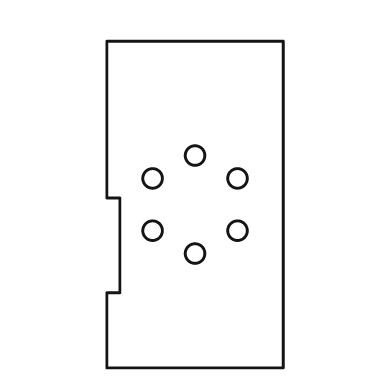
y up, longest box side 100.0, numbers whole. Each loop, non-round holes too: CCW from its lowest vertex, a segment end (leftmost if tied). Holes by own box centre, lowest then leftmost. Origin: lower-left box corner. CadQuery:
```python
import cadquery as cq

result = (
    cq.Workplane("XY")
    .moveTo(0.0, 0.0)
    .lineTo(54.0, 0.0)
    .lineTo(54.0, 100.0)
    .lineTo(0.0, 100.0)
    .lineTo(0.0, 52.0)
    .lineTo(4.0, 52.0)
    .lineTo(4.0, 23.0)
    .lineTo(0.0, 23.0)
    .close()
    .moveTo(27.0, 35.0)
    .circle(3.0)
    .moveTo(14.0, 42.0)
    .circle(3.0)
    .moveTo(40.0, 42.0)
    .circle(3.0)
    .moveTo(14.0, 58.0)
    .circle(3.0)
    .moveTo(40.0, 58.0)
    .circle(3.0)
    .moveTo(27.0, 65.0)
    .circle(3.0)
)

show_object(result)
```